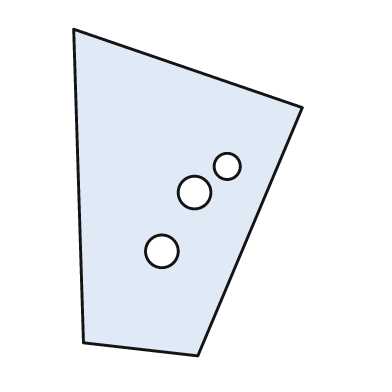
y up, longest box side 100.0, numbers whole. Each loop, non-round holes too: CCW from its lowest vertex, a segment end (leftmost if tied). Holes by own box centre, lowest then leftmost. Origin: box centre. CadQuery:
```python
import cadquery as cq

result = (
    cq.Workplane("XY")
    .moveTo(3.0, -50.0)
    .lineTo(35.0, 26.0)
    .lineTo(-35.0, 50.0)
    .lineTo(-32.0, -46.0)
    .close()
    .moveTo(-8.0, -18.0)
    .circle(5.0)
    .moveTo(2.0, 0.0)
    .circle(5.0)
    .moveTo(12.0, 8.0)
    .circle(4.0)
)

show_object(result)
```